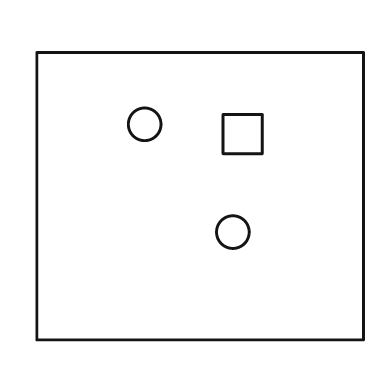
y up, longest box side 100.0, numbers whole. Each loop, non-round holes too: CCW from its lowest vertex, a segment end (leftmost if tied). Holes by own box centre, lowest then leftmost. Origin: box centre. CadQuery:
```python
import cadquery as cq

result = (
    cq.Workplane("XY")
    .moveTo(-50.0, -44.0)
    .lineTo(50.0, -44.0)
    .lineTo(50.0, 44.0)
    .lineTo(-50.0, 44.0)
    .close()
    .moveTo(10.0, -11.0)
    .circle(5.0)
    .moveTo(7.0, 13.0)
    .lineTo(19.0, 13.0)
    .lineTo(19.0, 25.0)
    .lineTo(7.0, 25.0)
    .close()
    .moveTo(-17.0, 22.0)
    .circle(5.0)
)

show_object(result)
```